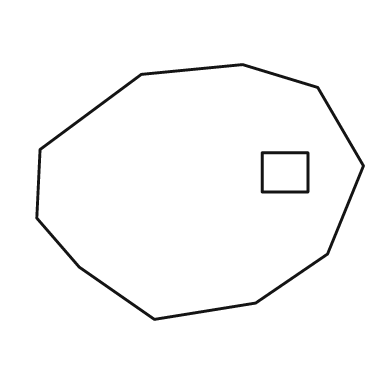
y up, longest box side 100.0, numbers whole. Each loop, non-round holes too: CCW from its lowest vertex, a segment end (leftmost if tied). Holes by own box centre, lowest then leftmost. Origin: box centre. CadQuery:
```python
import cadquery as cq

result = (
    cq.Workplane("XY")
    .moveTo(-14.0, -39.0)
    .lineTo(17.0, -34.0)
    .lineTo(39.0, -19.0)
    .lineTo(50.0, 8.0)
    .lineTo(36.0, 32.0)
    .lineTo(13.0, 39.0)
    .lineTo(-18.0, 36.0)
    .lineTo(-49.0, 13.0)
    .lineTo(-50.0, -8.0)
    .lineTo(-37.0, -23.0)
    .close()
    .moveTo(19.0, 0.0)
    .lineTo(33.0, 0.0)
    .lineTo(33.0, 12.0)
    .lineTo(19.0, 12.0)
    .close()
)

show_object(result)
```